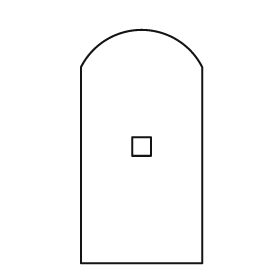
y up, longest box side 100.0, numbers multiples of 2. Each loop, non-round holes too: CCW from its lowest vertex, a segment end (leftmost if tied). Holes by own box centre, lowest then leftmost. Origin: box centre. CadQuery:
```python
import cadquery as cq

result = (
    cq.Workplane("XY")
    .moveTo(-26.0, -50.0)
    .lineTo(26.0, -50.0)
    .lineTo(26.0, 34.0)
    .threePointArc((0.0, 50.0), (-26.0, 34.0))
    .close()
    .moveTo(-4.0, -4.0)
    .lineTo(4.0, -4.0)
    .lineTo(4.0, 4.0)
    .lineTo(-4.0, 4.0)
    .close()
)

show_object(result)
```